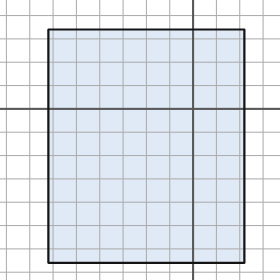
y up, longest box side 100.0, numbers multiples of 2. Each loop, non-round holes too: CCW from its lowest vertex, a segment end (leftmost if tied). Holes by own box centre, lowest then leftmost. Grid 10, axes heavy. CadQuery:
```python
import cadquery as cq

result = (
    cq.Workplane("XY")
    .moveTo(-62.0, -66.0)
    .lineTo(22.0, -66.0)
    .lineTo(22.0, 34.0)
    .lineTo(-62.0, 34.0)
    .close()
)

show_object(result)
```